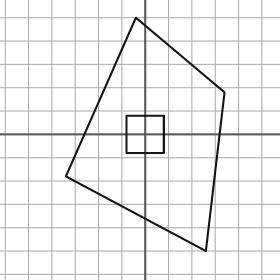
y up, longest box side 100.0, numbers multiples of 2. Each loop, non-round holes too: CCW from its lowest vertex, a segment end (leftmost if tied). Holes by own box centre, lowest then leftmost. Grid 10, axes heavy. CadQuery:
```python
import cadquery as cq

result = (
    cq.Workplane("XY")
    .moveTo(26.0, -50.0)
    .lineTo(34.0, 18.0)
    .lineTo(-4.0, 50.0)
    .lineTo(-34.0, -18.0)
    .close()
    .moveTo(-8.0, -8.0)
    .lineTo(8.0, -8.0)
    .lineTo(8.0, 8.0)
    .lineTo(-8.0, 8.0)
    .close()
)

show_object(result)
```